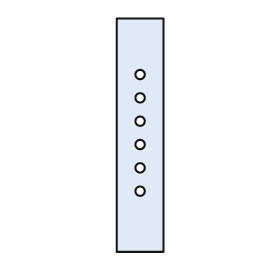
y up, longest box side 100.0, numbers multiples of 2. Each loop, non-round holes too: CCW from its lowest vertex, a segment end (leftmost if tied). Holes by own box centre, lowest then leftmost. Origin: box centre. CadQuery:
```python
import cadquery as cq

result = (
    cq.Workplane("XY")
    .moveTo(-10.0, -50.0)
    .lineTo(10.0, -50.0)
    .lineTo(10.0, 50.0)
    .lineTo(-10.0, 50.0)
    .close()
    .moveTo(0.0, -24.0)
    .circle(2.0)
    .moveTo(0.0, -14.0)
    .circle(2.0)
    .moveTo(0.0, -4.0)
    .circle(2.0)
    .moveTo(0.0, 6.0)
    .circle(2.0)
    .moveTo(0.0, 16.0)
    .circle(2.0)
    .moveTo(0.0, 26.0)
    .circle(2.0)
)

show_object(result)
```